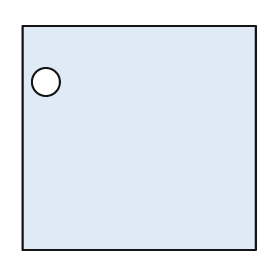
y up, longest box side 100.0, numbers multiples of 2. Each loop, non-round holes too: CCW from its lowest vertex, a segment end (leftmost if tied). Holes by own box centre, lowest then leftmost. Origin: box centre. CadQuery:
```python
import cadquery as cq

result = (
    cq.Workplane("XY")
    .moveTo(-50.0, -48.0)
    .lineTo(50.0, -48.0)
    .lineTo(50.0, 48.0)
    .lineTo(-50.0, 48.0)
    .close()
    .moveTo(-40.0, 24.0)
    .circle(6.0)
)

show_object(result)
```